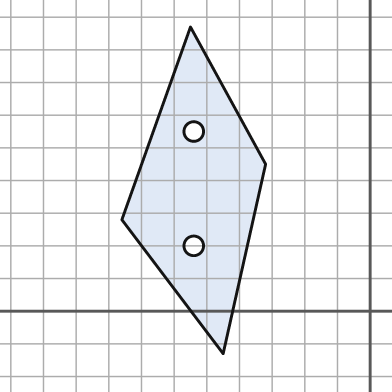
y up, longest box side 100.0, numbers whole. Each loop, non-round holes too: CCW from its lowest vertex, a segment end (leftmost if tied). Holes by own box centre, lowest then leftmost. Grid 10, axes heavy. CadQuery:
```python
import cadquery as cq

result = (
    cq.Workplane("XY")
    .moveTo(-45.0, -13.0)
    .lineTo(-32.0, 45.0)
    .lineTo(-55.0, 87.0)
    .lineTo(-76.0, 28.0)
    .close()
    .moveTo(-54.0, 20.0)
    .circle(3.0)
    .moveTo(-54.0, 55.0)
    .circle(3.0)
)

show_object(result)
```